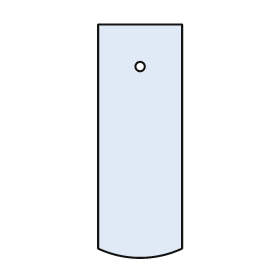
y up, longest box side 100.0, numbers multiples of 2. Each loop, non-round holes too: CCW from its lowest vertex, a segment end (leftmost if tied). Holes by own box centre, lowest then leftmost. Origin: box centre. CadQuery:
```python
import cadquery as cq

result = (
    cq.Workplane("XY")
    .moveTo(-18.0, -46.0)
    .threePointArc((0.0, -50.0), (18.0, -46.0))
    .lineTo(18.0, 50.0)
    .lineTo(-18.0, 50.0)
    .close()
    .moveTo(0.0, 32.0)
    .circle(2.0)
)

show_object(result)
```